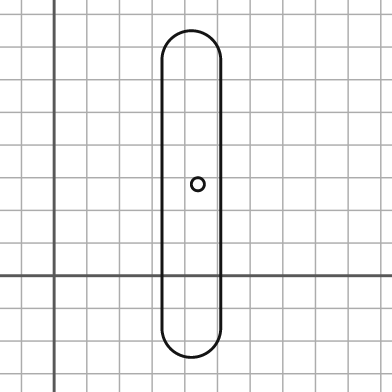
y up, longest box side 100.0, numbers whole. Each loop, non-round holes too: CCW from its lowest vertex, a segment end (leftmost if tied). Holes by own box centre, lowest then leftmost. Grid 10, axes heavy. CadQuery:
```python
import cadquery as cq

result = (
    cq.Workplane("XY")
    .moveTo(33.0, -16.0)
    .threePointArc((42.0, -25.0), (51.0, -16.0))
    .lineTo(51.0, 66.0)
    .threePointArc((42.0, 75.0), (33.0, 66.0))
    .close()
    .moveTo(44.0, 28.0)
    .circle(2.0)
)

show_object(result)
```